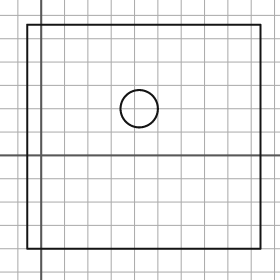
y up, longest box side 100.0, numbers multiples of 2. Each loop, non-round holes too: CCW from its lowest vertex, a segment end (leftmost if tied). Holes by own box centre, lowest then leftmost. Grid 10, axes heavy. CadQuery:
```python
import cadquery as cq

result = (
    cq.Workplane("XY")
    .moveTo(-6.0, -40.0)
    .lineTo(94.0, -40.0)
    .lineTo(94.0, 56.0)
    .lineTo(-6.0, 56.0)
    .close()
    .moveTo(42.0, 20.0)
    .circle(8.0)
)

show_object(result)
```